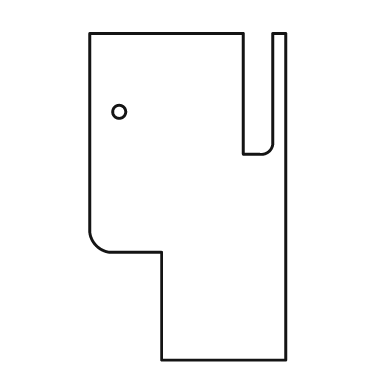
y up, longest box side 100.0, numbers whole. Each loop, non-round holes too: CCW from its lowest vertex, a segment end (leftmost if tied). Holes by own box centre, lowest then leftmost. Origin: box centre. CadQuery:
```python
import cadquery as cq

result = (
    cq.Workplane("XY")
    .moveTo(-8.0, -50.0)
    .lineTo(30.0, -50.0)
    .lineTo(30.0, 50.0)
    .lineTo(26.0, 50.0)
    .lineTo(26.0, 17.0)
    .threePointArc((25.0, 14.0), (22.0, 13.0))
    .lineTo(17.0, 13.0)
    .lineTo(17.0, 50.0)
    .lineTo(-30.0, 50.0)
    .lineTo(-30.0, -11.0)
    .threePointArc((-28.0, -15.0), (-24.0, -17.0))
    .lineTo(-8.0, -17.0)
    .close()
    .moveTo(-21.0, 26.0)
    .circle(2.0)
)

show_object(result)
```